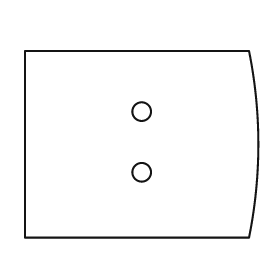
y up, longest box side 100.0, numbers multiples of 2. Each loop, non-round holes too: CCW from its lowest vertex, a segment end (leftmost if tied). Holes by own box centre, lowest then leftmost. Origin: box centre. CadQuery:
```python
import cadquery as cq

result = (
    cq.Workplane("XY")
    .moveTo(-50.0, -40.0)
    .lineTo(46.0, -40.0)
    .threePointArc((50.0, 0.0), (46.0, 40.0))
    .lineTo(-50.0, 40.0)
    .close()
    .moveTo(0.0, -12.0)
    .circle(4.0)
    .moveTo(0.0, 14.0)
    .circle(4.0)
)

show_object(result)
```